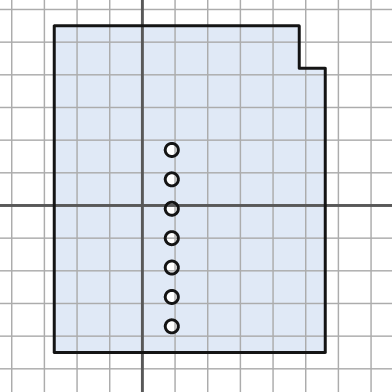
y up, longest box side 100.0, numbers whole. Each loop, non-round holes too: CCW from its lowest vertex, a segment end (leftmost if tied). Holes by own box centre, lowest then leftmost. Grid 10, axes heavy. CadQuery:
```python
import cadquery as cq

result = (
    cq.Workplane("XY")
    .moveTo(-27.0, -45.0)
    .lineTo(56.0, -45.0)
    .lineTo(56.0, 42.0)
    .lineTo(48.0, 42.0)
    .lineTo(48.0, 55.0)
    .lineTo(-27.0, 55.0)
    .close()
    .moveTo(9.0, -37.0)
    .circle(2.0)
    .moveTo(9.0, -28.0)
    .circle(2.0)
    .moveTo(9.0, -19.0)
    .circle(2.0)
    .moveTo(9.0, -10.0)
    .circle(2.0)
    .moveTo(9.0, -1.0)
    .circle(2.0)
    .moveTo(9.0, 8.0)
    .circle(2.0)
    .moveTo(9.0, 17.0)
    .circle(2.0)
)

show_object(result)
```